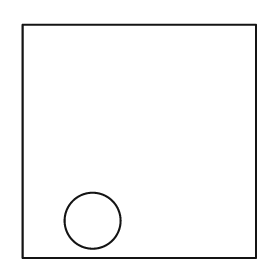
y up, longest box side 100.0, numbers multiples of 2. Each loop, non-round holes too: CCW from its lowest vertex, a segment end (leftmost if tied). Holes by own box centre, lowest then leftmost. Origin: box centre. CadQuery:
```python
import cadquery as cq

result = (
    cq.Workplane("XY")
    .moveTo(-50.0, -50.0)
    .lineTo(50.0, -50.0)
    .lineTo(50.0, 50.0)
    .lineTo(-50.0, 50.0)
    .close()
    .moveTo(-20.0, -34.0)
    .circle(12.0)
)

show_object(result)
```